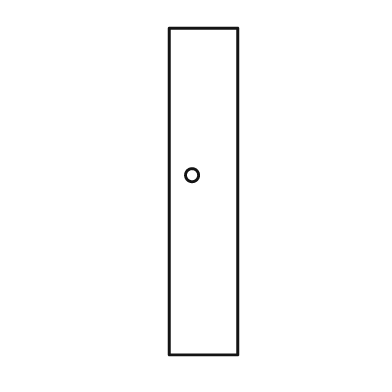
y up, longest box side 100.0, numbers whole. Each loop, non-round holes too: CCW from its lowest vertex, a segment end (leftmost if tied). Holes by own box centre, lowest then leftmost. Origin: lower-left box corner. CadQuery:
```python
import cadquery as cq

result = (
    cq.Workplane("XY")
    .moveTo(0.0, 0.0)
    .lineTo(21.0, 0.0)
    .lineTo(21.0, 100.0)
    .lineTo(0.0, 100.0)
    .close()
    .moveTo(7.0, 55.0)
    .circle(2.0)
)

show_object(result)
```